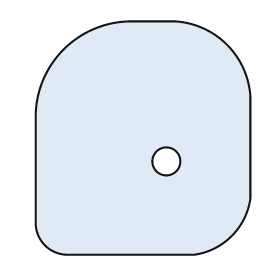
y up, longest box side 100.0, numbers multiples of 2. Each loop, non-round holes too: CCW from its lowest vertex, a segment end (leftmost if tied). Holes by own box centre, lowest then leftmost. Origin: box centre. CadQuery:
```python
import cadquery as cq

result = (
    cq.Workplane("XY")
    .moveTo(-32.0, -50.0)
    .lineTo(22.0, -50.0)
    .threePointArc((38.0, -42.0), (46.0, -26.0))
    .lineTo(46.0, 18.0)
    .threePointArc((36.0, 40.0), (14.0, 50.0))
    .lineTo(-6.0, 50.0)
    .threePointArc((-34.0, 38.0), (-46.0, 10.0))
    .lineTo(-46.0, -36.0)
    .threePointArc((-42.0, -46.0), (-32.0, -50.0))
    .close()
    .moveTo(10.0, -10.0)
    .circle(6.0)
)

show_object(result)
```